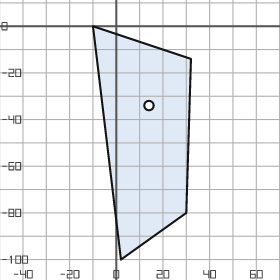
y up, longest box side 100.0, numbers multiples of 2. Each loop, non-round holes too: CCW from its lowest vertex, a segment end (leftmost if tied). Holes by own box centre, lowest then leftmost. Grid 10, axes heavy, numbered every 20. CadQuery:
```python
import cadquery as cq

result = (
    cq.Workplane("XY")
    .moveTo(2.0, -100.0)
    .lineTo(30.0, -80.0)
    .lineTo(32.0, -14.0)
    .lineTo(-10.0, 0.0)
    .close()
    .moveTo(14.0, -34.0)
    .circle(2.0)
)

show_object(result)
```